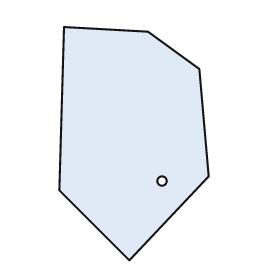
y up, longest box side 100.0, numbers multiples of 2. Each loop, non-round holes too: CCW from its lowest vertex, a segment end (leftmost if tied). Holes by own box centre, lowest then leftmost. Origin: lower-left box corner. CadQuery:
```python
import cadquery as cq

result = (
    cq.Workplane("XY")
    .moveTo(30.0, 0.0)
    .lineTo(64.0, 36.0)
    .lineTo(60.0, 82.0)
    .lineTo(38.0, 98.0)
    .lineTo(2.0, 100.0)
    .lineTo(0.0, 30.0)
    .close()
    .moveTo(44.0, 34.0)
    .circle(2.0)
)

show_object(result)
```